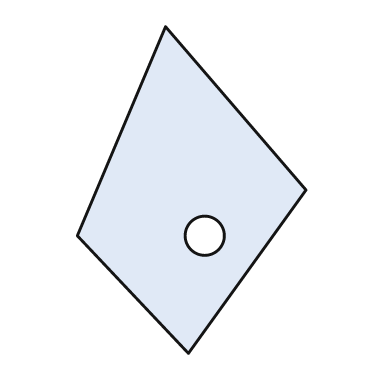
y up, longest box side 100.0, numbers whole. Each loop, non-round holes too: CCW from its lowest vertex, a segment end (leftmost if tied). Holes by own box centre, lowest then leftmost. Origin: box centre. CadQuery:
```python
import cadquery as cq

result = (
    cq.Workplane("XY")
    .moveTo(-1.0, -50.0)
    .lineTo(35.0, 0.0)
    .lineTo(-8.0, 50.0)
    .lineTo(-35.0, -14.0)
    .close()
    .moveTo(4.0, -14.0)
    .circle(6.0)
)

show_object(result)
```